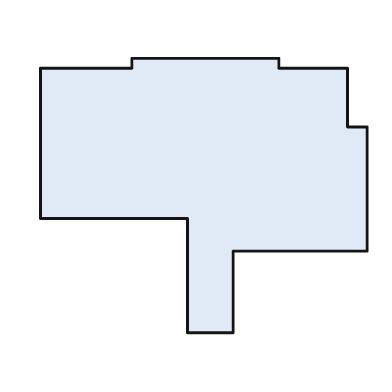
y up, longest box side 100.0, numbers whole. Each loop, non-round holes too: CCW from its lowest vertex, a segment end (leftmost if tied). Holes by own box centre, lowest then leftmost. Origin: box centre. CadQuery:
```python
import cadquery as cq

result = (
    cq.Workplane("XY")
    .moveTo(-5.0, -42.0)
    .lineTo(9.0, -42.0)
    .lineTo(9.0, -17.0)
    .lineTo(50.0, -17.0)
    .lineTo(50.0, 21.0)
    .lineTo(44.0, 21.0)
    .lineTo(44.0, 39.0)
    .lineTo(23.0, 39.0)
    .lineTo(23.0, 42.0)
    .lineTo(-22.0, 42.0)
    .lineTo(-22.0, 39.0)
    .lineTo(-50.0, 39.0)
    .lineTo(-50.0, -7.0)
    .lineTo(-5.0, -7.0)
    .close()
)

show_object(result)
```